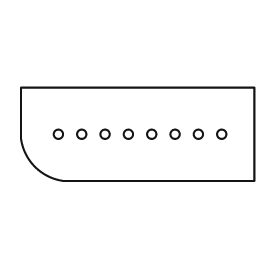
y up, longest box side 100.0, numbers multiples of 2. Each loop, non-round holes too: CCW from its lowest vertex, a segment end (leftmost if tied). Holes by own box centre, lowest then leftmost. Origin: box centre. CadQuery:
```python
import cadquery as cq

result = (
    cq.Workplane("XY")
    .moveTo(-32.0, -20.0)
    .lineTo(50.0, -20.0)
    .lineTo(50.0, 20.0)
    .lineTo(-50.0, 20.0)
    .lineTo(-50.0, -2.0)
    .threePointArc((-44.0, -14.0), (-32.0, -20.0))
    .close()
    .moveTo(-34.0, 0.0)
    .circle(2.0)
    .moveTo(-24.0, 0.0)
    .circle(2.0)
    .moveTo(-14.0, 0.0)
    .circle(2.0)
    .moveTo(-4.0, 0.0)
    .circle(2.0)
    .moveTo(6.0, 0.0)
    .circle(2.0)
    .moveTo(16.0, 0.0)
    .circle(2.0)
    .moveTo(26.0, 0.0)
    .circle(2.0)
    .moveTo(36.0, 0.0)
    .circle(2.0)
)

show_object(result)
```